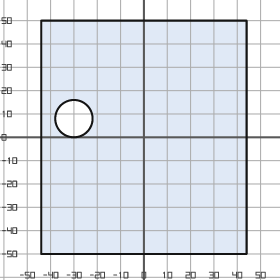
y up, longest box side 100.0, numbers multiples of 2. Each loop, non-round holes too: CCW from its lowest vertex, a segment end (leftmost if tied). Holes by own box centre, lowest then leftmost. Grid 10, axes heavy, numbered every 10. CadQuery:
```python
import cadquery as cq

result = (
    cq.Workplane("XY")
    .moveTo(-44.0, -50.0)
    .lineTo(44.0, -50.0)
    .lineTo(44.0, 50.0)
    .lineTo(-44.0, 50.0)
    .close()
    .moveTo(-30.0, 8.0)
    .circle(8.0)
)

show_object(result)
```